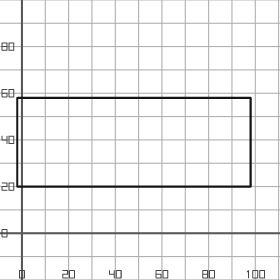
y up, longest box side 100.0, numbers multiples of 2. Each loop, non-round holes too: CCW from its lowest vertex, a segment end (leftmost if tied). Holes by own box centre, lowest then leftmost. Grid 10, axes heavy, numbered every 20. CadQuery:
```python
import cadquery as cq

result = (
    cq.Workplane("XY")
    .moveTo(-2.0, 20.0)
    .lineTo(98.0, 20.0)
    .lineTo(98.0, 58.0)
    .lineTo(-2.0, 58.0)
    .close()
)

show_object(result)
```